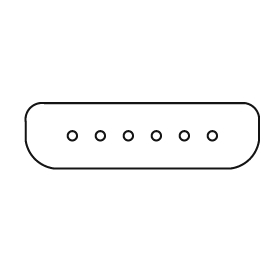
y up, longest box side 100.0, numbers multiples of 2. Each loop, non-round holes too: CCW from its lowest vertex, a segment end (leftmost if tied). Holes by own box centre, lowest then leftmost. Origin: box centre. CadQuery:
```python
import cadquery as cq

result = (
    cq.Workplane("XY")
    .moveTo(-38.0, -14.0)
    .lineTo(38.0, -14.0)
    .threePointArc((46.0, -10.0), (50.0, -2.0))
    .lineTo(50.0, 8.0)
    .threePointArc((48.0, 12.0), (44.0, 14.0))
    .lineTo(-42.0, 14.0)
    .threePointArc((-48.0, 12.0), (-50.0, 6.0))
    .lineTo(-50.0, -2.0)
    .threePointArc((-46.0, -10.0), (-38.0, -14.0))
    .close()
    .moveTo(-30.0, 0.0)
    .circle(2.0)
    .moveTo(-18.0, 0.0)
    .circle(2.0)
    .moveTo(-6.0, 0.0)
    .circle(2.0)
    .moveTo(6.0, 0.0)
    .circle(2.0)
    .moveTo(18.0, 0.0)
    .circle(2.0)
    .moveTo(30.0, 0.0)
    .circle(2.0)
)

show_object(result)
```